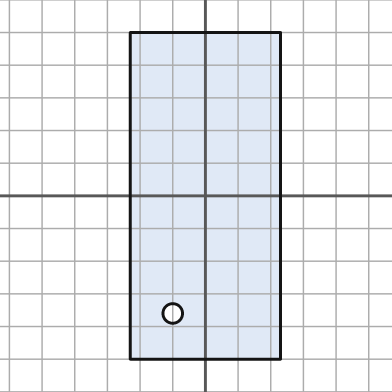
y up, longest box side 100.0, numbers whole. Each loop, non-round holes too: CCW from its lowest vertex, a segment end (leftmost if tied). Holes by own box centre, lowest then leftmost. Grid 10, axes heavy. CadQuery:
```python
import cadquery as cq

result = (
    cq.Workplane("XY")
    .moveTo(-23.0, -50.0)
    .lineTo(23.0, -50.0)
    .lineTo(23.0, 50.0)
    .lineTo(-23.0, 50.0)
    .close()
    .moveTo(-10.0, -36.0)
    .circle(3.0)
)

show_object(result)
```